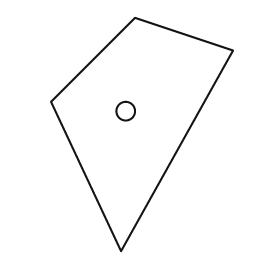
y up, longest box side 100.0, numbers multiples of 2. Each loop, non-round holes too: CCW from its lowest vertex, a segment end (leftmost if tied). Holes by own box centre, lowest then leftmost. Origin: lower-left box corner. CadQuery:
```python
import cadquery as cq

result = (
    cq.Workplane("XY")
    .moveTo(30.0, 0.0)
    .lineTo(78.0, 86.0)
    .lineTo(36.0, 100.0)
    .lineTo(0.0, 64.0)
    .close()
    .moveTo(32.0, 60.0)
    .circle(4.0)
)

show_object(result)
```